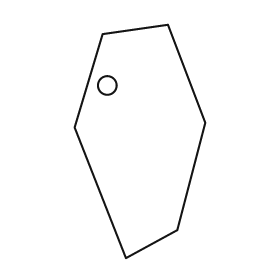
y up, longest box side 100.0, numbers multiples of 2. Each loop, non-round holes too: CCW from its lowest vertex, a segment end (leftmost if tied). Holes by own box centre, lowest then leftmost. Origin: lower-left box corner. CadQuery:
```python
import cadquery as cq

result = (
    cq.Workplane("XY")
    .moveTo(22.0, 0.0)
    .lineTo(44.0, 12.0)
    .lineTo(56.0, 58.0)
    .lineTo(40.0, 100.0)
    .lineTo(12.0, 96.0)
    .lineTo(0.0, 56.0)
    .close()
    .moveTo(14.0, 74.0)
    .circle(4.0)
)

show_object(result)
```